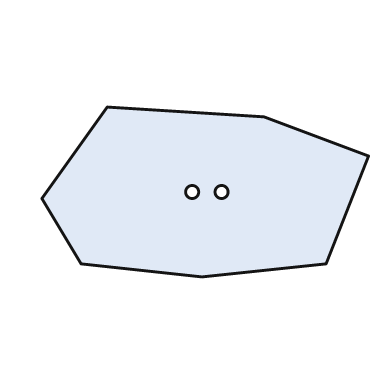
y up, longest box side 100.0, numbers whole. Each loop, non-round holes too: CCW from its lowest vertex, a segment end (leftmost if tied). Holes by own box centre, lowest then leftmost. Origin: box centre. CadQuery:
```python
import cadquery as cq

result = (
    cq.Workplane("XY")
    .moveTo(-1.0, -26.0)
    .lineTo(37.0, -22.0)
    .lineTo(50.0, 11.0)
    .lineTo(18.0, 23.0)
    .lineTo(-30.0, 26.0)
    .lineTo(-50.0, -2.0)
    .lineTo(-38.0, -22.0)
    .close()
    .moveTo(-4.0, 0.0)
    .circle(2.0)
    .moveTo(5.0, 0.0)
    .circle(2.0)
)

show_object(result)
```